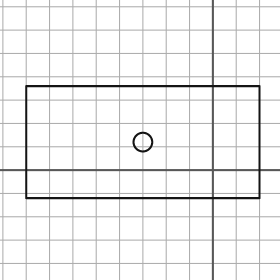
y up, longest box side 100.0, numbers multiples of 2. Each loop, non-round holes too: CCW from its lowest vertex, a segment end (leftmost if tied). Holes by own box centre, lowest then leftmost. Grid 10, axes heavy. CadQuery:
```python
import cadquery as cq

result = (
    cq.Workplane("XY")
    .moveTo(-80.0, -12.0)
    .lineTo(20.0, -12.0)
    .lineTo(20.0, 36.0)
    .lineTo(-80.0, 36.0)
    .close()
    .moveTo(-30.0, 12.0)
    .circle(4.0)
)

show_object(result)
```